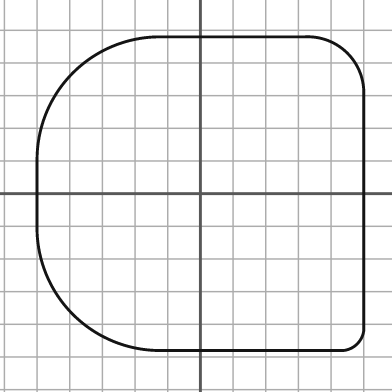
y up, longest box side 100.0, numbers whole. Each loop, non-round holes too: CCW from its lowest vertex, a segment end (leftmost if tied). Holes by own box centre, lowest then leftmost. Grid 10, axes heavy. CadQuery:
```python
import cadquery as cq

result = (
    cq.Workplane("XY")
    .moveTo(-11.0, -48.0)
    .lineTo(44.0, -48.0)
    .threePointArc((48.0, -46.0), (50.0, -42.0))
    .lineTo(50.0, 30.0)
    .threePointArc((45.0, 43.0), (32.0, 48.0))
    .lineTo(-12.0, 48.0)
    .threePointArc((-39.0, 37.0), (-50.0, 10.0))
    .lineTo(-50.0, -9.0)
    .threePointArc((-39.0, -37.0), (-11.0, -48.0))
    .close()
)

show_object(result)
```